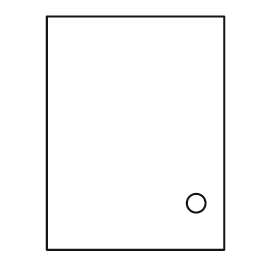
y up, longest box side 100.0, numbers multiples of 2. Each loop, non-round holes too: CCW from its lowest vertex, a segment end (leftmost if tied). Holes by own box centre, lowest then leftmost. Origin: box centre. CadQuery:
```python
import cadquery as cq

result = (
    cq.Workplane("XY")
    .moveTo(-38.0, -50.0)
    .lineTo(38.0, -50.0)
    .lineTo(38.0, 50.0)
    .lineTo(-38.0, 50.0)
    .close()
    .moveTo(26.0, -30.0)
    .circle(4.0)
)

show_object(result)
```